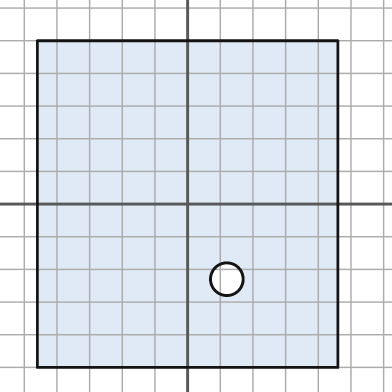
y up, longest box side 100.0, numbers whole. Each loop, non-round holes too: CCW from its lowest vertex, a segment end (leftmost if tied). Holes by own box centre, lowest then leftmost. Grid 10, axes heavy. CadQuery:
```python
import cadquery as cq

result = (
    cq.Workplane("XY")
    .moveTo(-46.0, -50.0)
    .lineTo(46.0, -50.0)
    .lineTo(46.0, 50.0)
    .lineTo(-46.0, 50.0)
    .close()
    .moveTo(12.0, -23.0)
    .circle(5.0)
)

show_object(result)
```